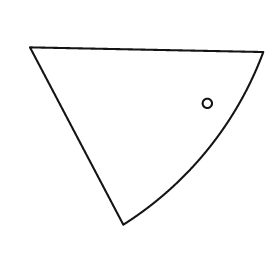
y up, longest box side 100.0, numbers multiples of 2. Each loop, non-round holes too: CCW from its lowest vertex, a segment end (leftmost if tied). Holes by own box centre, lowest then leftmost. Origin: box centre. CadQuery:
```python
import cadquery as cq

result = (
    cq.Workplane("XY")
    .moveTo(-10.0, -38.0)
    .threePointArc((26.0, -6.0), (50.0, 36.0))
    .lineTo(-50.0, 38.0)
    .close()
    .moveTo(26.0, 14.0)
    .circle(2.0)
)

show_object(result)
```